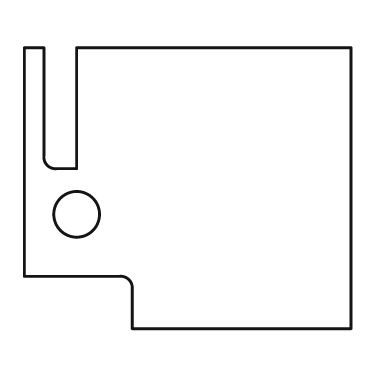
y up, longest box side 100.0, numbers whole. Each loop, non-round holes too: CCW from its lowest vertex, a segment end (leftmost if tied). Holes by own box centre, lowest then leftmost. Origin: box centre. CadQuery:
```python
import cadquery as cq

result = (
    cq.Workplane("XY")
    .moveTo(-17.0, -43.0)
    .lineTo(50.0, -43.0)
    .lineTo(50.0, 43.0)
    .lineTo(-34.0, 43.0)
    .lineTo(-34.0, 6.0)
    .lineTo(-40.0, 6.0)
    .threePointArc((-43.0, 7.0), (-44.0, 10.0))
    .lineTo(-44.0, 43.0)
    .lineTo(-50.0, 43.0)
    .lineTo(-50.0, -27.0)
    .lineTo(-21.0, -27.0)
    .threePointArc((-18.0, -28.0), (-17.0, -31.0))
    .close()
    .moveTo(-34.0, -8.0)
    .circle(7.0)
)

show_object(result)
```